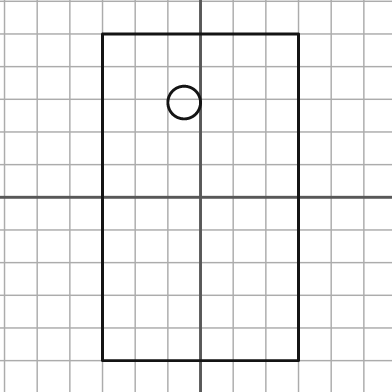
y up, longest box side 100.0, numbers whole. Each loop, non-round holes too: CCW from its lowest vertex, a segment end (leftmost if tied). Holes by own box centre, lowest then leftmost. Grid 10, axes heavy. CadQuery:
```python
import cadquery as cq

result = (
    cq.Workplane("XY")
    .moveTo(-30.0, -50.0)
    .lineTo(30.0, -50.0)
    .lineTo(30.0, 50.0)
    .lineTo(-30.0, 50.0)
    .close()
    .moveTo(-5.0, 29.0)
    .circle(5.0)
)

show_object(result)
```